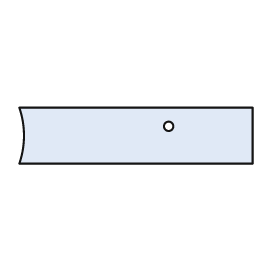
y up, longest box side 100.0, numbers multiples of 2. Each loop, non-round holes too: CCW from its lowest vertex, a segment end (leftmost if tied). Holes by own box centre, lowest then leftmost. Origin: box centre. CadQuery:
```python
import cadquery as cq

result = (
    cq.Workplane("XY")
    .moveTo(-50.0, -12.0)
    .lineTo(50.0, -12.0)
    .lineTo(50.0, 12.0)
    .lineTo(-50.0, 12.0)
    .threePointArc((-48.0, 0.0), (-50.0, -12.0))
    .close()
    .moveTo(14.0, 4.0)
    .circle(2.0)
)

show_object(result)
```